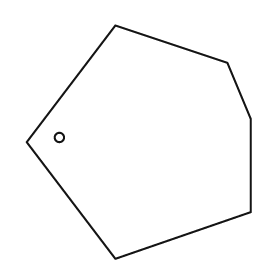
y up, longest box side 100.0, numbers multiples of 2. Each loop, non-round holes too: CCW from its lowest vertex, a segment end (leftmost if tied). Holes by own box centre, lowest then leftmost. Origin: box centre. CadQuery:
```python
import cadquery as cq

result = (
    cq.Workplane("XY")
    .moveTo(-10.0, -50.0)
    .lineTo(48.0, -30.0)
    .lineTo(48.0, 10.0)
    .lineTo(38.0, 34.0)
    .lineTo(-10.0, 50.0)
    .lineTo(-48.0, 0.0)
    .close()
    .moveTo(-34.0, 2.0)
    .circle(2.0)
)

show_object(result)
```